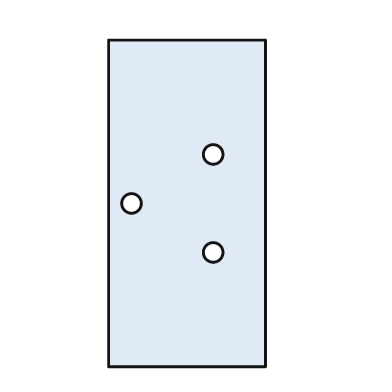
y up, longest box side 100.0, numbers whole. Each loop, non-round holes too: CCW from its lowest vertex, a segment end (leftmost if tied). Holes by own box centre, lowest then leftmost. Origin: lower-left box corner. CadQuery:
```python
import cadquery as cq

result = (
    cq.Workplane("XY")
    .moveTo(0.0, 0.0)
    .lineTo(48.0, 0.0)
    .lineTo(48.0, 100.0)
    .lineTo(0.0, 100.0)
    .close()
    .moveTo(32.0, 35.0)
    .circle(3.0)
    .moveTo(7.0, 50.0)
    .circle(3.0)
    .moveTo(32.0, 65.0)
    .circle(3.0)
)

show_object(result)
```